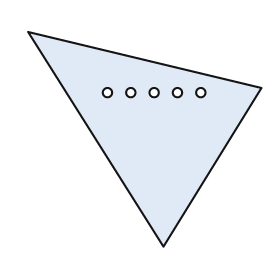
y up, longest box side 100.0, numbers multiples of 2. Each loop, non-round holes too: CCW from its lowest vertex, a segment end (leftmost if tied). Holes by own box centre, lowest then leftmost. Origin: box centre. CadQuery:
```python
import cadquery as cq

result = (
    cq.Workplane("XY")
    .moveTo(8.0, -46.0)
    .lineTo(50.0, 22.0)
    .lineTo(-50.0, 46.0)
    .close()
    .moveTo(-16.0, 20.0)
    .circle(2.0)
    .moveTo(-6.0, 20.0)
    .circle(2.0)
    .moveTo(4.0, 20.0)
    .circle(2.0)
    .moveTo(14.0, 20.0)
    .circle(2.0)
    .moveTo(24.0, 20.0)
    .circle(2.0)
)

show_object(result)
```